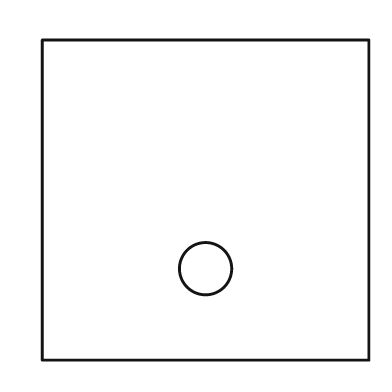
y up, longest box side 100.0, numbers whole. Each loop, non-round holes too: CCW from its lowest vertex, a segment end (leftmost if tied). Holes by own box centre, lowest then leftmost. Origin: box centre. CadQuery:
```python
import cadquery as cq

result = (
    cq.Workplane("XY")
    .moveTo(-50.0, -49.0)
    .lineTo(50.0, -49.0)
    .lineTo(50.0, 49.0)
    .lineTo(-50.0, 49.0)
    .close()
    .moveTo(0.0, -21.0)
    .circle(8.0)
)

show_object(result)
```